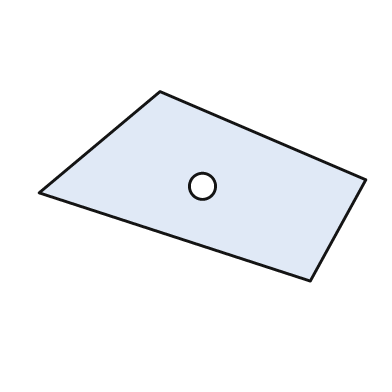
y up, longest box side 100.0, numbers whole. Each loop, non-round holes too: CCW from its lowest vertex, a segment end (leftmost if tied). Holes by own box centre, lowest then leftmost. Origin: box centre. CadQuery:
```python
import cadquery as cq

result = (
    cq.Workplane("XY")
    .moveTo(33.0, -29.0)
    .lineTo(50.0, 2.0)
    .lineTo(-13.0, 29.0)
    .lineTo(-50.0, -2.0)
    .close()
    .moveTo(0.0, 0.0)
    .circle(4.0)
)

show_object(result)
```